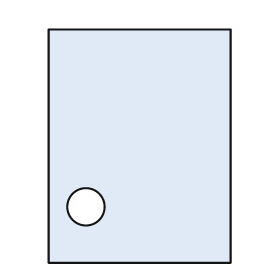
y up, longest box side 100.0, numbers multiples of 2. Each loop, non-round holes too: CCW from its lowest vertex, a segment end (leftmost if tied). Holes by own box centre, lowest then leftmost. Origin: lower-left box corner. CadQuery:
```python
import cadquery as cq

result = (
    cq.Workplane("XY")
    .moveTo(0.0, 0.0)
    .lineTo(78.0, 0.0)
    .lineTo(78.0, 100.0)
    .lineTo(0.0, 100.0)
    .close()
    .moveTo(16.0, 24.0)
    .circle(8.0)
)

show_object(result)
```